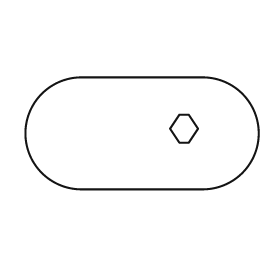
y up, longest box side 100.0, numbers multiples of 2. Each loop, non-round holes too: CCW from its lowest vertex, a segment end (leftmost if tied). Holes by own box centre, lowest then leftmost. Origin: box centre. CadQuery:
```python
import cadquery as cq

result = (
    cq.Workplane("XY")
    .moveTo(-26.0, -24.0)
    .lineTo(26.0, -24.0)
    .threePointArc((50.0, 0.0), (26.0, 24.0))
    .lineTo(-26.0, 24.0)
    .threePointArc((-50.0, 0.0), (-26.0, -24.0))
    .close()
    .moveTo(16.0, -4.0)
    .lineTo(20.0, -4.0)
    .lineTo(24.0, 2.0)
    .lineTo(20.0, 8.0)
    .lineTo(16.0, 8.0)
    .lineTo(12.0, 2.0)
    .close()
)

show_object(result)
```